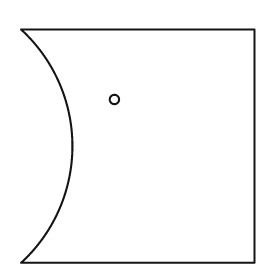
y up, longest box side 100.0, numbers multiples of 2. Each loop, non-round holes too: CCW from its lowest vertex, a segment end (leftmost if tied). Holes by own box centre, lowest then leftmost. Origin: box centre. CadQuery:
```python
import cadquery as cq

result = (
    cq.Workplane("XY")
    .moveTo(-50.0, -50.0)
    .lineTo(50.0, -50.0)
    .lineTo(50.0, 50.0)
    .lineTo(-50.0, 50.0)
    .threePointArc((-28.0, 0.0), (-50.0, -50.0))
    .close()
    .moveTo(-10.0, 20.0)
    .circle(2.0)
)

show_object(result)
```